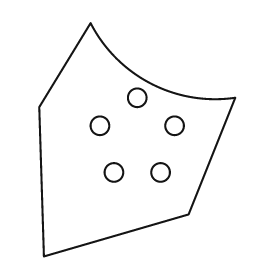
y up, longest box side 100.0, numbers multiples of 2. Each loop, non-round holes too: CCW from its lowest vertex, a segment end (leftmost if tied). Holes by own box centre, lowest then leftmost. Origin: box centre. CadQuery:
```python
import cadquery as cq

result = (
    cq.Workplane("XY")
    .moveTo(-40.0, -50.0)
    .lineTo(22.0, -32.0)
    .lineTo(42.0, 18.0)
    .threePointArc((6.0, 24.0), (-20.0, 50.0))
    .lineTo(-42.0, 14.0)
    .close()
    .moveTo(-10.0, -14.0)
    .circle(4.0)
    .moveTo(10.0, -14.0)
    .circle(4.0)
    .moveTo(-16.0, 6.0)
    .circle(4.0)
    .moveTo(16.0, 6.0)
    .circle(4.0)
    .moveTo(0.0, 18.0)
    .circle(4.0)
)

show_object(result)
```